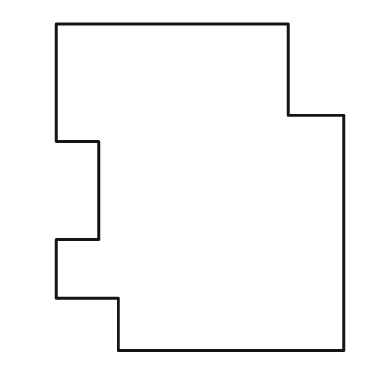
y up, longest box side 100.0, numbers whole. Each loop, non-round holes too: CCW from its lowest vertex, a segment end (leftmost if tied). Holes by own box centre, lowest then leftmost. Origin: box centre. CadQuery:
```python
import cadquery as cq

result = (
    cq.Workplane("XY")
    .moveTo(-25.0, -50.0)
    .lineTo(44.0, -50.0)
    .lineTo(44.0, 22.0)
    .lineTo(27.0, 22.0)
    .lineTo(27.0, 50.0)
    .lineTo(-44.0, 50.0)
    .lineTo(-44.0, 14.0)
    .lineTo(-31.0, 14.0)
    .lineTo(-31.0, -16.0)
    .lineTo(-44.0, -16.0)
    .lineTo(-44.0, -34.0)
    .lineTo(-25.0, -34.0)
    .close()
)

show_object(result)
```